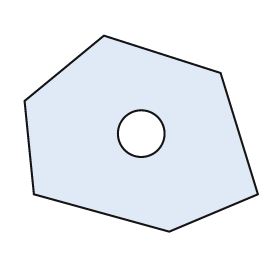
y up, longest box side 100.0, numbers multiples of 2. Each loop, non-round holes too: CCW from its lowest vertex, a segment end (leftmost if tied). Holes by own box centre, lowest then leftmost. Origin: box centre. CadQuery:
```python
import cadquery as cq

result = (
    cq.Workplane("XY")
    .moveTo(12.0, -42.0)
    .lineTo(50.0, -26.0)
    .lineTo(34.0, 26.0)
    .lineTo(-16.0, 42.0)
    .lineTo(-50.0, 14.0)
    .lineTo(-46.0, -26.0)
    .close()
    .moveTo(0.0, 0.0)
    .circle(10.0)
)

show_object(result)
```